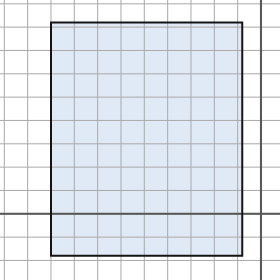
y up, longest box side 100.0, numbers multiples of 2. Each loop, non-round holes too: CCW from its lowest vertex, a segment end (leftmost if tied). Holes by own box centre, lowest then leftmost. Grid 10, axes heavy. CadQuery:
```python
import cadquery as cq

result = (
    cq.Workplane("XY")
    .moveTo(-90.0, -18.0)
    .lineTo(-8.0, -18.0)
    .lineTo(-8.0, 82.0)
    .lineTo(-90.0, 82.0)
    .close()
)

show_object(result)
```